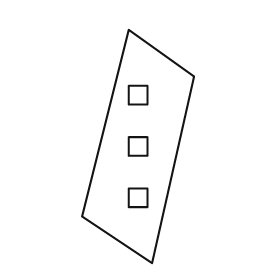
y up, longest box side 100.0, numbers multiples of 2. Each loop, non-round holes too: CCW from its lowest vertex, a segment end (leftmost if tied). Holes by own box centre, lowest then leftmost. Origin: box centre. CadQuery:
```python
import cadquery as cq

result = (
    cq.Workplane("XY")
    .moveTo(6.0, -50.0)
    .lineTo(24.0, 30.0)
    .lineTo(-4.0, 50.0)
    .lineTo(-24.0, -30.0)
    .close()
    .moveTo(-4.0, -26.0)
    .lineTo(4.0, -26.0)
    .lineTo(4.0, -18.0)
    .lineTo(-4.0, -18.0)
    .close()
    .moveTo(-4.0, -4.0)
    .lineTo(4.0, -4.0)
    .lineTo(4.0, 4.0)
    .lineTo(-4.0, 4.0)
    .close()
    .moveTo(-4.0, 18.0)
    .lineTo(4.0, 18.0)
    .lineTo(4.0, 26.0)
    .lineTo(-4.0, 26.0)
    .close()
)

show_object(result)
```